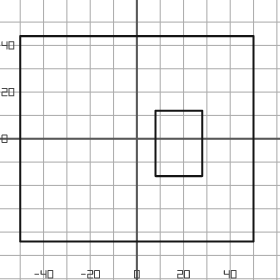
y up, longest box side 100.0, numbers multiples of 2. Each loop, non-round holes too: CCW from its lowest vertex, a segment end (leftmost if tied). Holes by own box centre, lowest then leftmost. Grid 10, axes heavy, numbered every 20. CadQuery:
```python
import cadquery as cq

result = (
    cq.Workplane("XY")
    .moveTo(-50.0, -44.0)
    .lineTo(50.0, -44.0)
    .lineTo(50.0, 44.0)
    .lineTo(-50.0, 44.0)
    .close()
    .moveTo(8.0, -16.0)
    .lineTo(28.0, -16.0)
    .lineTo(28.0, 12.0)
    .lineTo(8.0, 12.0)
    .close()
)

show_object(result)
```